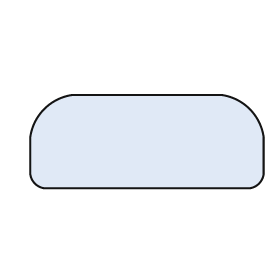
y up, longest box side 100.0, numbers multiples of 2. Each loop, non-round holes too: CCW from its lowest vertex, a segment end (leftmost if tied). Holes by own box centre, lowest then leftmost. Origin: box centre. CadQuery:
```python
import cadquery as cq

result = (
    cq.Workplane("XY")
    .moveTo(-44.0, -20.0)
    .lineTo(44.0, -20.0)
    .threePointArc((48.0, -18.0), (50.0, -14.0))
    .lineTo(50.0, 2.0)
    .threePointArc((44.0, 14.0), (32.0, 20.0))
    .lineTo(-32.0, 20.0)
    .threePointArc((-44.0, 14.0), (-50.0, 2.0))
    .lineTo(-50.0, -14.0)
    .threePointArc((-48.0, -18.0), (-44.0, -20.0))
    .close()
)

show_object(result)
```